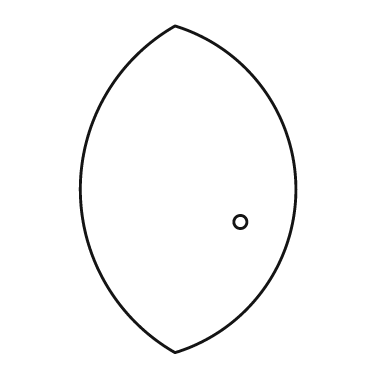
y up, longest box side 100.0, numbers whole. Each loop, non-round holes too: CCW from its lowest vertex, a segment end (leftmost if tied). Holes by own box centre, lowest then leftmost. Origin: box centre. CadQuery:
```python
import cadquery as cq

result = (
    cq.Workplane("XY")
    .moveTo(-4.0, -50.0)
    .threePointArc((33.0, 0.0), (-4.0, 50.0))
    .threePointArc((-33.0, 0.0), (-4.0, -50.0))
    .close()
    .moveTo(16.0, -10.0)
    .circle(2.0)
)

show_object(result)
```